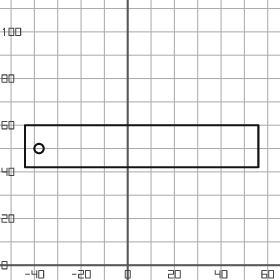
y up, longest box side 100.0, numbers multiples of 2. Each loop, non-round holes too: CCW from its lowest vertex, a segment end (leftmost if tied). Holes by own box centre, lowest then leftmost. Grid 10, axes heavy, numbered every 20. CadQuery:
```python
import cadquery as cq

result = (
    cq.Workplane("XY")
    .moveTo(-44.0, 42.0)
    .lineTo(56.0, 42.0)
    .lineTo(56.0, 60.0)
    .lineTo(-44.0, 60.0)
    .close()
    .moveTo(-38.0, 50.0)
    .circle(2.0)
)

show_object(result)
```